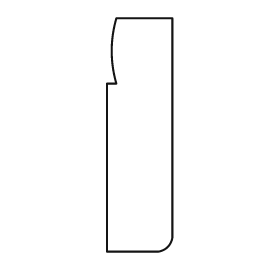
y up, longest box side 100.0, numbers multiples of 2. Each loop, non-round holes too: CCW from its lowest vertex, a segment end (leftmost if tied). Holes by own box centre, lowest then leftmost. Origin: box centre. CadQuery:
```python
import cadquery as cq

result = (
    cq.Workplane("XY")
    .moveTo(-14.0, -50.0)
    .lineTo(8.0, -50.0)
    .threePointArc((12.0, -48.0), (14.0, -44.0))
    .lineTo(14.0, 50.0)
    .lineTo(-10.0, 50.0)
    .threePointArc((-12.0, 36.0), (-10.0, 22.0))
    .lineTo(-14.0, 22.0)
    .close()
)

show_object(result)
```